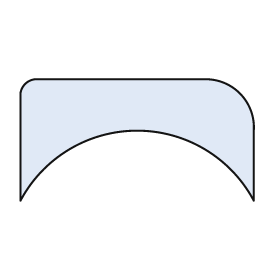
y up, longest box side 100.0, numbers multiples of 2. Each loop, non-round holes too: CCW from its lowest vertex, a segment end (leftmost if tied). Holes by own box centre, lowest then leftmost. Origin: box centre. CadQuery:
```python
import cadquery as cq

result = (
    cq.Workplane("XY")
    .moveTo(-50.0, -26.0)
    .threePointArc((0.0, 4.0), (50.0, -26.0))
    .lineTo(50.0, 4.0)
    .threePointArc((44.0, 20.0), (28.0, 26.0))
    .lineTo(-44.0, 26.0)
    .threePointArc((-48.0, 24.0), (-50.0, 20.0))
    .close()
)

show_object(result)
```